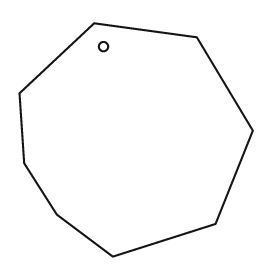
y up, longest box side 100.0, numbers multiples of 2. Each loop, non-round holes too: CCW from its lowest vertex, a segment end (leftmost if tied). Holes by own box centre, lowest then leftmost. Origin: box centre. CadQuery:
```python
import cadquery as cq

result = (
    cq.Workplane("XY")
    .moveTo(-10.0, -50.0)
    .lineTo(34.0, -36.0)
    .lineTo(50.0, 4.0)
    .lineTo(26.0, 44.0)
    .lineTo(-18.0, 50.0)
    .lineTo(-50.0, 20.0)
    .lineTo(-48.0, -10.0)
    .lineTo(-34.0, -32.0)
    .close()
    .moveTo(-14.0, 40.0)
    .circle(2.0)
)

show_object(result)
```